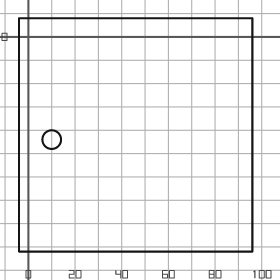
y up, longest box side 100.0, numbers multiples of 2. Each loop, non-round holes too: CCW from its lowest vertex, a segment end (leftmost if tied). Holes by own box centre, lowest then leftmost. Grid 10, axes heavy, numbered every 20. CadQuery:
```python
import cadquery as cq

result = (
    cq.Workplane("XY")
    .moveTo(-4.0, -92.0)
    .lineTo(96.0, -92.0)
    .lineTo(96.0, 8.0)
    .lineTo(-4.0, 8.0)
    .close()
    .moveTo(10.0, -44.0)
    .circle(4.0)
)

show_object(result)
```